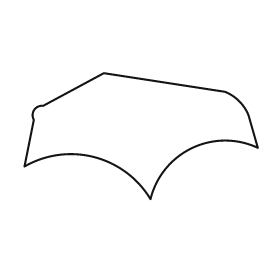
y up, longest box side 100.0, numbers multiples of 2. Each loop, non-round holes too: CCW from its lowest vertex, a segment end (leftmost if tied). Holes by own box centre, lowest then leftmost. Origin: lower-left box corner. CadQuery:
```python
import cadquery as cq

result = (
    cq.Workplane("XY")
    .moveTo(54.0, 0.0)
    .threePointArc((72.0, 22.0), (100.0, 22.0))
    .lineTo(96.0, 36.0)
    .threePointArc((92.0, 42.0), (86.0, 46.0))
    .lineTo(34.0, 54.0)
    .lineTo(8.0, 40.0)
    .threePointArc((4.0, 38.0), (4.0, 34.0))
    .lineTo(0.0, 14.0)
    .threePointArc((30.0, 18.0), (54.0, 0.0))
    .close()
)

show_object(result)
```